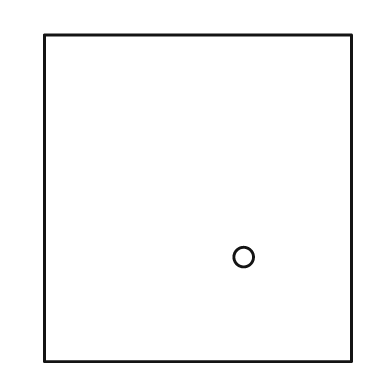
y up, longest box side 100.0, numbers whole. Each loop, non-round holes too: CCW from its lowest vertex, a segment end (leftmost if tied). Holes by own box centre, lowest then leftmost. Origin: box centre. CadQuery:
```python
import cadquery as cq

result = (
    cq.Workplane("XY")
    .moveTo(-47.0, -50.0)
    .lineTo(47.0, -50.0)
    .lineTo(47.0, 50.0)
    .lineTo(-47.0, 50.0)
    .close()
    .moveTo(14.0, -18.0)
    .circle(3.0)
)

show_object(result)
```